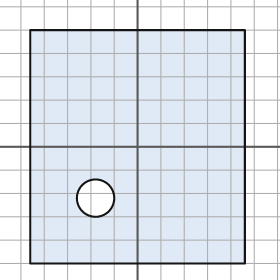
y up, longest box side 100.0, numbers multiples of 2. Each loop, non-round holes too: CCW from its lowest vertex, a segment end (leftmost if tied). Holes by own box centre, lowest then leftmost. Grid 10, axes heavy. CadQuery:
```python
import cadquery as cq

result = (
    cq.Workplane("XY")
    .moveTo(-46.0, -50.0)
    .lineTo(46.0, -50.0)
    .lineTo(46.0, 50.0)
    .lineTo(-46.0, 50.0)
    .close()
    .moveTo(-18.0, -22.0)
    .circle(8.0)
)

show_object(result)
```